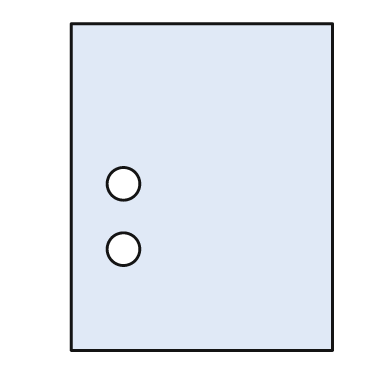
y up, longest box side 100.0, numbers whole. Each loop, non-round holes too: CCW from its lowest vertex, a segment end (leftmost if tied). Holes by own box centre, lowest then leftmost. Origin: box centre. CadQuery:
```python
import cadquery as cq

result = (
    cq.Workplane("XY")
    .moveTo(-40.0, -50.0)
    .lineTo(40.0, -50.0)
    .lineTo(40.0, 50.0)
    .lineTo(-40.0, 50.0)
    .close()
    .moveTo(-24.0, -19.0)
    .circle(5.0)
    .moveTo(-24.0, 1.0)
    .circle(5.0)
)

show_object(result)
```